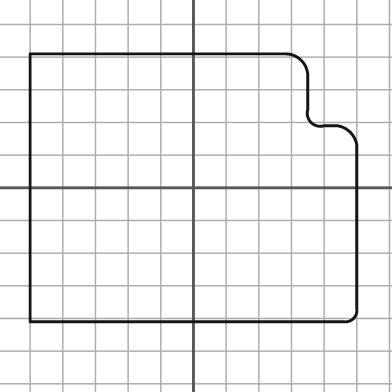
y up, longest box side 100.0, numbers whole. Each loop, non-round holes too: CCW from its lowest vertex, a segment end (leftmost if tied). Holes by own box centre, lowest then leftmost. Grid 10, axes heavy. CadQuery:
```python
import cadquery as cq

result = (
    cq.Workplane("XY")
    .moveTo(-50.0, -41.0)
    .lineTo(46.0, -41.0)
    .threePointArc((49.0, -40.0), (50.0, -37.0))
    .lineTo(50.0, 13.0)
    .threePointArc((48.0, 17.0), (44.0, 19.0))
    .lineTo(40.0, 19.0)
    .threePointArc((36.0, 20.0), (35.0, 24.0))
    .lineTo(35.0, 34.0)
    .threePointArc((33.0, 39.0), (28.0, 41.0))
    .lineTo(-50.0, 41.0)
    .close()
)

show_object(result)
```